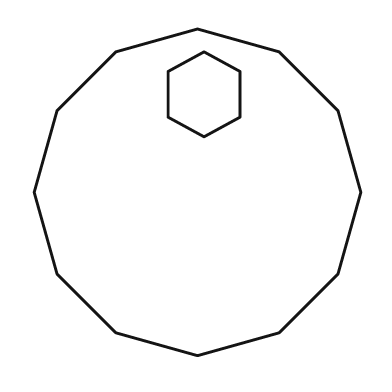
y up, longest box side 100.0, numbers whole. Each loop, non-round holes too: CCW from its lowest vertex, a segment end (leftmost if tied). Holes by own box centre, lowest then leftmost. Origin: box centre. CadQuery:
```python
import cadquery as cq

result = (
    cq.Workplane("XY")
    .moveTo(0.0, -50.0)
    .lineTo(25.0, -43.0)
    .lineTo(43.0, -25.0)
    .lineTo(50.0, 0.0)
    .lineTo(43.0, 25.0)
    .lineTo(25.0, 43.0)
    .lineTo(0.0, 50.0)
    .lineTo(-25.0, 43.0)
    .lineTo(-43.0, 25.0)
    .lineTo(-50.0, 0.0)
    .lineTo(-43.0, -25.0)
    .lineTo(-25.0, -43.0)
    .close()
    .moveTo(2.0, 17.0)
    .lineTo(13.0, 23.0)
    .lineTo(13.0, 37.0)
    .lineTo(2.0, 43.0)
    .lineTo(-9.0, 37.0)
    .lineTo(-9.0, 23.0)
    .close()
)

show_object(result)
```